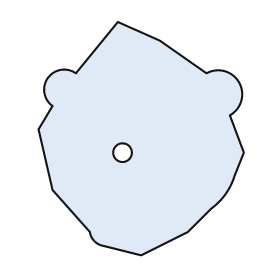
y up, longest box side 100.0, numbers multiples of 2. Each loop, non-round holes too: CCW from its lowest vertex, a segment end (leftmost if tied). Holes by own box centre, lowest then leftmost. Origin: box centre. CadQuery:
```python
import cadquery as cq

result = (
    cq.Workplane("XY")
    .moveTo(0.0, -50.0)
    .lineTo(20.0, -40.0)
    .lineTo(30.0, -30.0)
    .threePointArc((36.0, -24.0), (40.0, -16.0))
    .lineTo(44.0, -6.0)
    .lineTo(38.0, 10.0)
    .threePointArc((42.0, 24.0), (28.0, 28.0))
    .lineTo(8.0, 42.0)
    .lineTo(-10.0, 50.0)
    .lineTo(-28.0, 28.0)
    .threePointArc((-40.0, 26.0), (-38.0, 14.0))
    .lineTo(-44.0, 4.0)
    .lineTo(-38.0, -22.0)
    .lineTo(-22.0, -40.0)
    .threePointArc((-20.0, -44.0), (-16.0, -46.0))
    .close()
    .moveTo(-8.0, -6.0)
    .circle(4.0)
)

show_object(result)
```